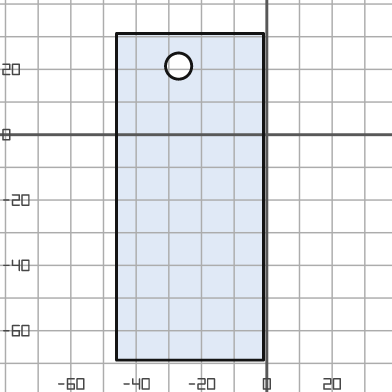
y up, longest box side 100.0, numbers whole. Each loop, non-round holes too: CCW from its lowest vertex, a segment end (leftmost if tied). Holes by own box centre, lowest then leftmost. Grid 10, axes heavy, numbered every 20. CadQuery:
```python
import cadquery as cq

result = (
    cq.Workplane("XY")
    .moveTo(-46.0, -69.0)
    .lineTo(-1.0, -69.0)
    .lineTo(-1.0, 31.0)
    .lineTo(-46.0, 31.0)
    .close()
    .moveTo(-27.0, 21.0)
    .circle(4.0)
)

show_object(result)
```